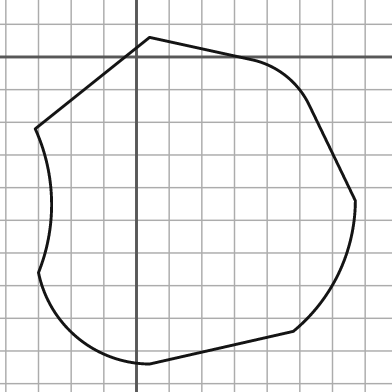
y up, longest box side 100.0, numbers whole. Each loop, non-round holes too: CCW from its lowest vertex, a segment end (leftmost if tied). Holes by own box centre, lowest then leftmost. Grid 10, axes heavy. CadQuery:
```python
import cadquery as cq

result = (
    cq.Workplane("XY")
    .moveTo(4.0, -94.0)
    .lineTo(48.0, -84.0)
    .threePointArc((62.0, -66.0), (67.0, -44.0))
    .lineTo(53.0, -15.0)
    .threePointArc((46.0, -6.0), (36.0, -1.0))
    .lineTo(4.0, 6.0)
    .lineTo(-31.0, -22.0)
    .threePointArc((-26.0, -44.0), (-30.0, -66.0))
    .threePointArc((-18.0, -86.0), (4.0, -94.0))
    .close()
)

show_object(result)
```